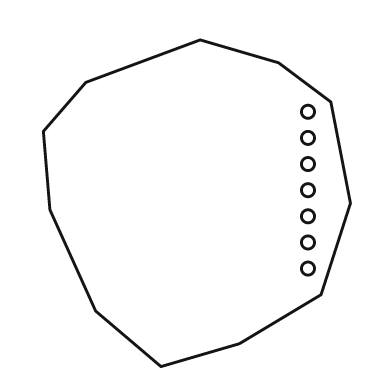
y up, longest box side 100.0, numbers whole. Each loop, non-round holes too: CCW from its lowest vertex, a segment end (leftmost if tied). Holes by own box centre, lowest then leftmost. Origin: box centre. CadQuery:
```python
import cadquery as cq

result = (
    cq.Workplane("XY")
    .moveTo(-11.0, -50.0)
    .lineTo(13.0, -43.0)
    .lineTo(38.0, -28.0)
    .lineTo(47.0, 0.0)
    .lineTo(41.0, 31.0)
    .lineTo(25.0, 43.0)
    .lineTo(1.0, 50.0)
    .lineTo(-34.0, 37.0)
    .lineTo(-47.0, 22.0)
    .lineTo(-45.0, -2.0)
    .lineTo(-31.0, -33.0)
    .close()
    .moveTo(34.0, -20.0)
    .circle(2.0)
    .moveTo(34.0, -12.0)
    .circle(2.0)
    .moveTo(34.0, -4.0)
    .circle(2.0)
    .moveTo(34.0, 4.0)
    .circle(2.0)
    .moveTo(34.0, 12.0)
    .circle(2.0)
    .moveTo(34.0, 20.0)
    .circle(2.0)
    .moveTo(34.0, 28.0)
    .circle(2.0)
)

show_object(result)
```